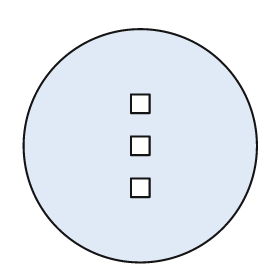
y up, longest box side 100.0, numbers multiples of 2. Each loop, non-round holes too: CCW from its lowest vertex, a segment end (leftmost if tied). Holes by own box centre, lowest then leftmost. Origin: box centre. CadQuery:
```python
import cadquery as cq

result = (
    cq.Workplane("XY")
    .moveTo(0.0, 0.0)
    .circle(50.0)
    .moveTo(-4.0, -22.0)
    .lineTo(4.0, -22.0)
    .lineTo(4.0, -14.0)
    .lineTo(-4.0, -14.0)
    .close()
    .moveTo(-4.0, -4.0)
    .lineTo(4.0, -4.0)
    .lineTo(4.0, 4.0)
    .lineTo(-4.0, 4.0)
    .close()
    .moveTo(-4.0, 14.0)
    .lineTo(4.0, 14.0)
    .lineTo(4.0, 22.0)
    .lineTo(-4.0, 22.0)
    .close()
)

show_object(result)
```